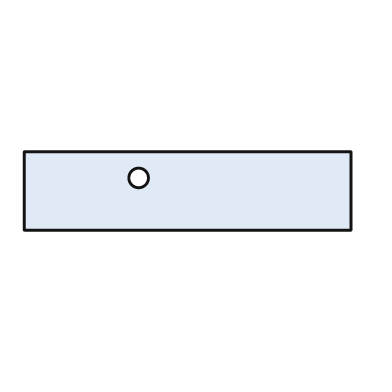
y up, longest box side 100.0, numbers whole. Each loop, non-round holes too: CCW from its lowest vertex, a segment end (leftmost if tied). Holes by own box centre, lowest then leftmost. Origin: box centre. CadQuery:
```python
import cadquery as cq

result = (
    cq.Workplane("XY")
    .moveTo(-50.0, -12.0)
    .lineTo(50.0, -12.0)
    .lineTo(50.0, 12.0)
    .lineTo(-50.0, 12.0)
    .close()
    .moveTo(-15.0, 4.0)
    .circle(3.0)
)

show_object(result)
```